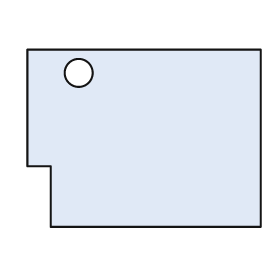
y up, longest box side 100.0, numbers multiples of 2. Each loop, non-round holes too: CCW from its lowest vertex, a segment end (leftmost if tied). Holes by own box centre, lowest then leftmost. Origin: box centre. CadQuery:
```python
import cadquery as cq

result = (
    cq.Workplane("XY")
    .moveTo(-40.0, -38.0)
    .lineTo(50.0, -38.0)
    .lineTo(50.0, 38.0)
    .lineTo(-50.0, 38.0)
    .lineTo(-50.0, -12.0)
    .lineTo(-40.0, -12.0)
    .close()
    .moveTo(-28.0, 28.0)
    .circle(6.0)
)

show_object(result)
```